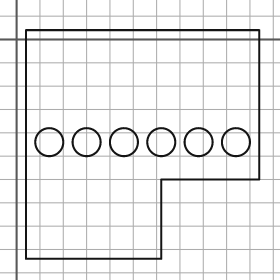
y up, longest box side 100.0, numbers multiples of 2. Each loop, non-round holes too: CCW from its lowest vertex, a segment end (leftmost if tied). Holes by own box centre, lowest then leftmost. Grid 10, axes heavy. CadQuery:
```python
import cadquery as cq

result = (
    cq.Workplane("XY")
    .moveTo(4.0, -94.0)
    .lineTo(62.0, -94.0)
    .lineTo(62.0, -60.0)
    .lineTo(104.0, -60.0)
    .lineTo(104.0, 4.0)
    .lineTo(4.0, 4.0)
    .close()
    .moveTo(14.0, -44.0)
    .circle(6.0)
    .moveTo(30.0, -44.0)
    .circle(6.0)
    .moveTo(46.0, -44.0)
    .circle(6.0)
    .moveTo(62.0, -44.0)
    .circle(6.0)
    .moveTo(78.0, -44.0)
    .circle(6.0)
    .moveTo(94.0, -44.0)
    .circle(6.0)
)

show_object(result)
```